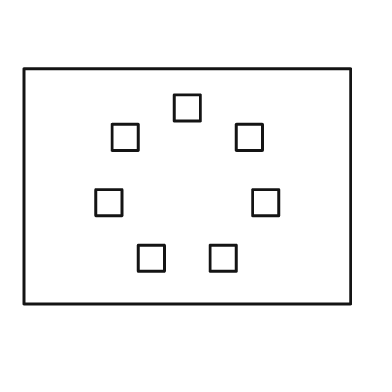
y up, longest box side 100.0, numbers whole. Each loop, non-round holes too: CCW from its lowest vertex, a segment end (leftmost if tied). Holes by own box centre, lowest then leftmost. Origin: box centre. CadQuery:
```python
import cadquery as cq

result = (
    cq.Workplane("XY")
    .moveTo(-50.0, -36.0)
    .lineTo(50.0, -36.0)
    .lineTo(50.0, 36.0)
    .lineTo(-50.0, 36.0)
    .close()
    .moveTo(-15.0, -26.0)
    .lineTo(-7.0, -26.0)
    .lineTo(-7.0, -18.0)
    .lineTo(-15.0, -18.0)
    .close()
    .moveTo(7.0, -26.0)
    .lineTo(15.0, -26.0)
    .lineTo(15.0, -18.0)
    .lineTo(7.0, -18.0)
    .close()
    .moveTo(-28.0, -9.0)
    .lineTo(-20.0, -9.0)
    .lineTo(-20.0, -1.0)
    .lineTo(-28.0, -1.0)
    .close()
    .moveTo(20.0, -9.0)
    .lineTo(28.0, -9.0)
    .lineTo(28.0, -1.0)
    .lineTo(20.0, -1.0)
    .close()
    .moveTo(-23.0, 11.0)
    .lineTo(-15.0, 11.0)
    .lineTo(-15.0, 19.0)
    .lineTo(-23.0, 19.0)
    .close()
    .moveTo(15.0, 11.0)
    .lineTo(23.0, 11.0)
    .lineTo(23.0, 19.0)
    .lineTo(15.0, 19.0)
    .close()
    .moveTo(-4.0, 20.0)
    .lineTo(4.0, 20.0)
    .lineTo(4.0, 28.0)
    .lineTo(-4.0, 28.0)
    .close()
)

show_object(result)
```